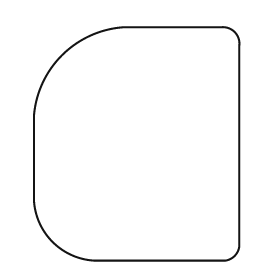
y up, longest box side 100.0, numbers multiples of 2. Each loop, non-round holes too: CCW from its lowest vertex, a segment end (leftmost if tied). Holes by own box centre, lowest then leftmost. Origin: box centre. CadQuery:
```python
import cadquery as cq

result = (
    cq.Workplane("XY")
    .moveTo(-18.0, -50.0)
    .lineTo(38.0, -50.0)
    .threePointArc((42.0, -48.0), (44.0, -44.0))
    .lineTo(44.0, 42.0)
    .threePointArc((42.0, 48.0), (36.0, 50.0))
    .lineTo(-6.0, 50.0)
    .threePointArc((-32.0, 38.0), (-44.0, 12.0))
    .lineTo(-44.0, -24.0)
    .threePointArc((-36.0, -42.0), (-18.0, -50.0))
    .close()
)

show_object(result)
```